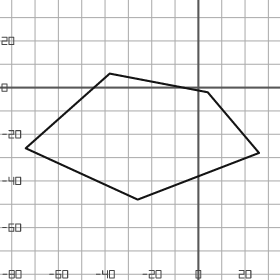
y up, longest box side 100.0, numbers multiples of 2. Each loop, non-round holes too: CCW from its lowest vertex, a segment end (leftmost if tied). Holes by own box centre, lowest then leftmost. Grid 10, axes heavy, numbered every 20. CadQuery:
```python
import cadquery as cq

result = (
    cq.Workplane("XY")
    .moveTo(-26.0, -48.0)
    .lineTo(26.0, -28.0)
    .lineTo(4.0, -2.0)
    .lineTo(-38.0, 6.0)
    .lineTo(-74.0, -26.0)
    .close()
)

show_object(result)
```